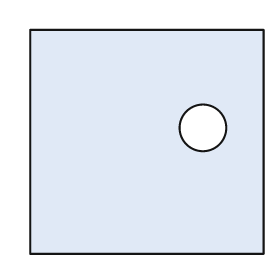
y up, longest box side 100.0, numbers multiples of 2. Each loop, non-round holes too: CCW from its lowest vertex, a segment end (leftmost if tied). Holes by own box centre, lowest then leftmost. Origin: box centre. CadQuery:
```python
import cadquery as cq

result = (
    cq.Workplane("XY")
    .moveTo(-50.0, -48.0)
    .lineTo(50.0, -48.0)
    .lineTo(50.0, 48.0)
    .lineTo(-50.0, 48.0)
    .close()
    .moveTo(24.0, 6.0)
    .circle(10.0)
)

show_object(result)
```